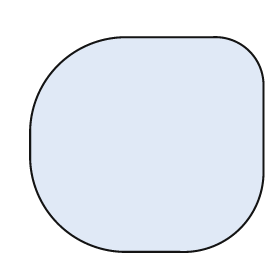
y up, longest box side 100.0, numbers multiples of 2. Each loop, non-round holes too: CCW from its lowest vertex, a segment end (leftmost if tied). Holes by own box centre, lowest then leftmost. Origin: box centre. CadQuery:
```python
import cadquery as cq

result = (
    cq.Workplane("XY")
    .moveTo(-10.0, -46.0)
    .lineTo(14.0, -46.0)
    .threePointArc((40.0, -36.0), (50.0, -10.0))
    .lineTo(50.0, 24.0)
    .threePointArc((44.0, 40.0), (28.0, 46.0))
    .lineTo(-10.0, 46.0)
    .threePointArc((-38.0, 34.0), (-50.0, 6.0))
    .lineTo(-50.0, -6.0)
    .threePointArc((-38.0, -34.0), (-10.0, -46.0))
    .close()
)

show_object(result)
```